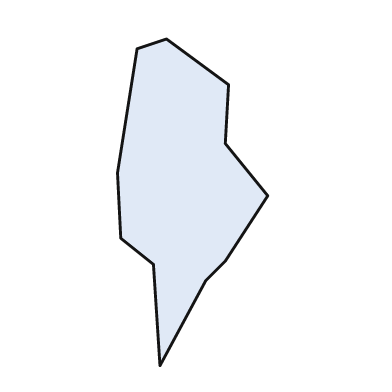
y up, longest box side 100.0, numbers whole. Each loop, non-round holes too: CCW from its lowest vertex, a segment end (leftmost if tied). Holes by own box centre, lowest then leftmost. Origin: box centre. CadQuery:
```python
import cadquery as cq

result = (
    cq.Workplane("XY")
    .moveTo(-10.0, -50.0)
    .lineTo(4.0, -24.0)
    .lineTo(10.0, -18.0)
    .lineTo(23.0, 2.0)
    .lineTo(10.0, 18.0)
    .lineTo(11.0, 36.0)
    .lineTo(-8.0, 50.0)
    .lineTo(-17.0, 47.0)
    .lineTo(-23.0, 9.0)
    .lineTo(-22.0, -11.0)
    .lineTo(-12.0, -19.0)
    .close()
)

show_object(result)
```